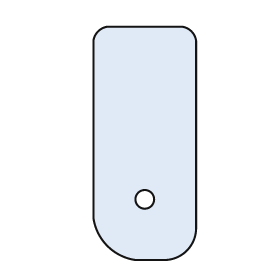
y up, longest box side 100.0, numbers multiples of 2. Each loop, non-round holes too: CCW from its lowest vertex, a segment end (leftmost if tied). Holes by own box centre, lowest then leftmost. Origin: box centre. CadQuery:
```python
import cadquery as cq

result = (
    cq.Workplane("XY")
    .moveTo(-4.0, -50.0)
    .lineTo(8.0, -50.0)
    .threePointArc((18.0, -46.0), (22.0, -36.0))
    .lineTo(22.0, 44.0)
    .threePointArc((20.0, 48.0), (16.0, 50.0))
    .lineTo(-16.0, 50.0)
    .threePointArc((-20.0, 48.0), (-22.0, 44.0))
    .lineTo(-22.0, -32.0)
    .threePointArc((-16.0, -44.0), (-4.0, -50.0))
    .close()
    .moveTo(0.0, -24.0)
    .circle(4.0)
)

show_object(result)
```